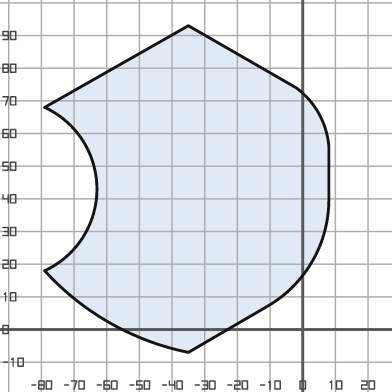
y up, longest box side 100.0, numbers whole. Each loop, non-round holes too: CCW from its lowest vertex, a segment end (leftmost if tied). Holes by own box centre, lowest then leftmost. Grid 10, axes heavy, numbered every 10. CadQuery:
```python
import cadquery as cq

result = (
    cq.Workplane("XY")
    .moveTo(-35.0, -7.0)
    .lineTo(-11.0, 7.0)
    .threePointArc((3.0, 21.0), (8.0, 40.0))
    .lineTo(8.0, 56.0)
    .threePointArc((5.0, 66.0), (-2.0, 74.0))
    .lineTo(-35.0, 93.0)
    .lineTo(-79.0, 68.0)
    .threePointArc((-63.0, 43.0), (-79.0, 18.0))
    .threePointArc((-59.0, 2.0), (-35.0, -7.0))
    .close()
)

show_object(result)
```